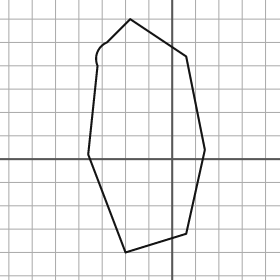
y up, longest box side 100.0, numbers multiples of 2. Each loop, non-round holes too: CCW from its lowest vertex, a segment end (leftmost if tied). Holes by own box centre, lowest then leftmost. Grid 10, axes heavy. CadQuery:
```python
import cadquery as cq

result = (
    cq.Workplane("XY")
    .moveTo(-20.0, -40.0)
    .lineTo(6.0, -32.0)
    .lineTo(14.0, 4.0)
    .lineTo(6.0, 44.0)
    .lineTo(-18.0, 60.0)
    .lineTo(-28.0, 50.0)
    .threePointArc((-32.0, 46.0), (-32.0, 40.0))
    .lineTo(-36.0, 2.0)
    .close()
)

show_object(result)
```